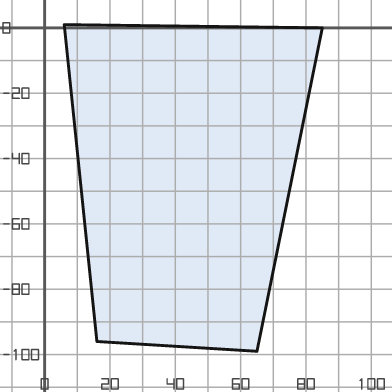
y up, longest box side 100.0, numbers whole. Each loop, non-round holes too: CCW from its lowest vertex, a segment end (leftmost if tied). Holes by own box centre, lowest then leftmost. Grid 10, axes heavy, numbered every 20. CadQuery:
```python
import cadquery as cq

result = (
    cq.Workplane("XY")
    .moveTo(65.0, -99.0)
    .lineTo(85.0, 0.0)
    .lineTo(6.0, 1.0)
    .lineTo(16.0, -96.0)
    .close()
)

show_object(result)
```